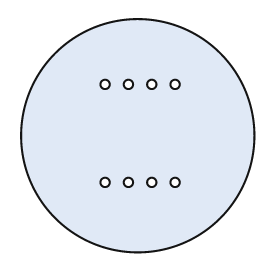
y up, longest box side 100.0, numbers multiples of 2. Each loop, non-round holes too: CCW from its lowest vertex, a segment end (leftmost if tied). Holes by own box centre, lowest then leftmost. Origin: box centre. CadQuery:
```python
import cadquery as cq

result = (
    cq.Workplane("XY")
    .moveTo(0.0, 0.0)
    .circle(50.0)
    .moveTo(-14.0, -20.0)
    .circle(2.0)
    .moveTo(-4.0, -20.0)
    .circle(2.0)
    .moveTo(6.0, -20.0)
    .circle(2.0)
    .moveTo(16.0, -20.0)
    .circle(2.0)
    .moveTo(-14.0, 22.0)
    .circle(2.0)
    .moveTo(-4.0, 22.0)
    .circle(2.0)
    .moveTo(6.0, 22.0)
    .circle(2.0)
    .moveTo(16.0, 22.0)
    .circle(2.0)
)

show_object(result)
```